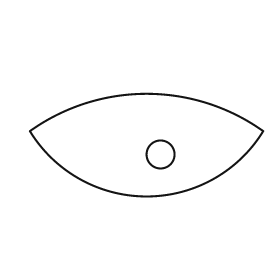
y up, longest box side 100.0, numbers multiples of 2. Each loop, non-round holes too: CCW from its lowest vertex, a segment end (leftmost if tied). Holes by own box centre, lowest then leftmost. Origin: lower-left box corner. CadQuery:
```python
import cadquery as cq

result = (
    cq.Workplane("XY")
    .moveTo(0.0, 28.0)
    .threePointArc((50.0, 0.0), (100.0, 28.0))
    .threePointArc((50.0, 44.0), (0.0, 28.0))
    .close()
    .moveTo(56.0, 18.0)
    .circle(6.0)
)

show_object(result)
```